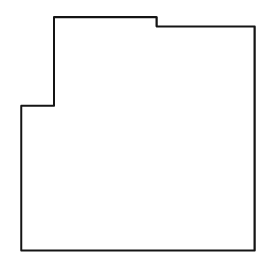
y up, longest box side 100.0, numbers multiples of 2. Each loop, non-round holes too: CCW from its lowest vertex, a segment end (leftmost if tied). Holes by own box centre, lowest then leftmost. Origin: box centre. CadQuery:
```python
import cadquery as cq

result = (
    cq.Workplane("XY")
    .moveTo(-50.0, -50.0)
    .lineTo(50.0, -50.0)
    .lineTo(50.0, 46.0)
    .lineTo(8.0, 46.0)
    .lineTo(8.0, 50.0)
    .lineTo(-36.0, 50.0)
    .lineTo(-36.0, 12.0)
    .lineTo(-50.0, 12.0)
    .close()
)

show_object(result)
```